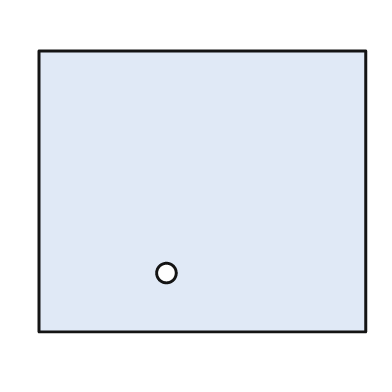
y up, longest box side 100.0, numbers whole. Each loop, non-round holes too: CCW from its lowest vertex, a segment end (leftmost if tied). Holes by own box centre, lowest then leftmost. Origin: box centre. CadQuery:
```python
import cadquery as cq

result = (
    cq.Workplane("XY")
    .moveTo(-50.0, -43.0)
    .lineTo(50.0, -43.0)
    .lineTo(50.0, 43.0)
    .lineTo(-50.0, 43.0)
    .close()
    .moveTo(-11.0, -25.0)
    .circle(3.0)
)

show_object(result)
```